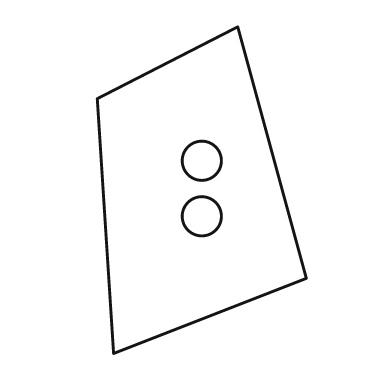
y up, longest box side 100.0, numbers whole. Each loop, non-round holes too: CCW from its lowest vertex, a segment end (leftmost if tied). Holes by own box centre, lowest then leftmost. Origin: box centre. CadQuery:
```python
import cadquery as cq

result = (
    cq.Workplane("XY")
    .moveTo(-27.0, -50.0)
    .lineTo(32.0, -27.0)
    .lineTo(11.0, 50.0)
    .lineTo(-32.0, 28.0)
    .close()
    .moveTo(0.0, -8.0)
    .circle(6.0)
    .moveTo(0.0, 9.0)
    .circle(6.0)
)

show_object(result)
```